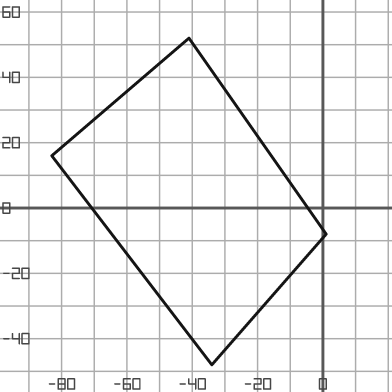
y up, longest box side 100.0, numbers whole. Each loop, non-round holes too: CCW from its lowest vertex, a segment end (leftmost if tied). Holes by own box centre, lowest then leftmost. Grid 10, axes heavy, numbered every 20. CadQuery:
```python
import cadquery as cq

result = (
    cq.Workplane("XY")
    .moveTo(-34.0, -48.0)
    .lineTo(1.0, -8.0)
    .lineTo(-41.0, 52.0)
    .lineTo(-83.0, 16.0)
    .close()
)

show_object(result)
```